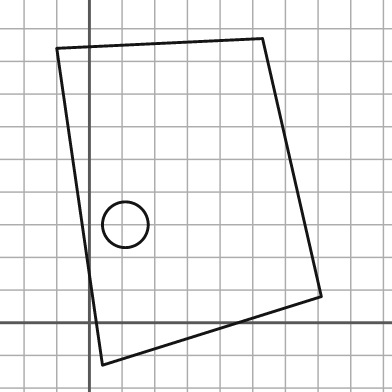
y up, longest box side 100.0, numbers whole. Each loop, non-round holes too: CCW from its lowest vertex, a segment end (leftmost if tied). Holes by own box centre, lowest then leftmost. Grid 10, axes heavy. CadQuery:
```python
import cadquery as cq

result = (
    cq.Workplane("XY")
    .moveTo(4.0, -13.0)
    .lineTo(71.0, 8.0)
    .lineTo(53.0, 87.0)
    .lineTo(-10.0, 84.0)
    .close()
    .moveTo(11.0, 30.0)
    .circle(7.0)
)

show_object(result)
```